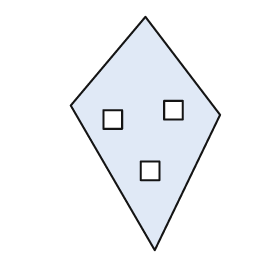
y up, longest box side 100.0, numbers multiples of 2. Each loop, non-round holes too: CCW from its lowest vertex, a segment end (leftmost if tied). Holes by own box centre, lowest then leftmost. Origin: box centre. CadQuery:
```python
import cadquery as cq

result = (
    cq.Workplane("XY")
    .moveTo(4.0, -50.0)
    .lineTo(32.0, 8.0)
    .lineTo(0.0, 50.0)
    .lineTo(-32.0, 12.0)
    .close()
    .moveTo(-2.0, -20.0)
    .lineTo(6.0, -20.0)
    .lineTo(6.0, -12.0)
    .lineTo(-2.0, -12.0)
    .close()
    .moveTo(-18.0, 2.0)
    .lineTo(-10.0, 2.0)
    .lineTo(-10.0, 10.0)
    .lineTo(-18.0, 10.0)
    .close()
    .moveTo(8.0, 6.0)
    .lineTo(16.0, 6.0)
    .lineTo(16.0, 14.0)
    .lineTo(8.0, 14.0)
    .close()
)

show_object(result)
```